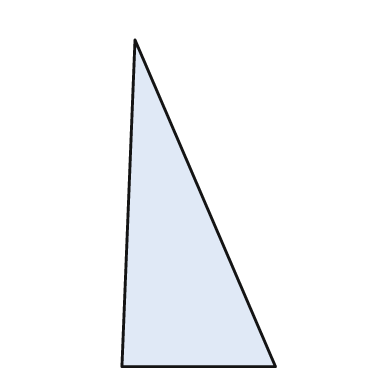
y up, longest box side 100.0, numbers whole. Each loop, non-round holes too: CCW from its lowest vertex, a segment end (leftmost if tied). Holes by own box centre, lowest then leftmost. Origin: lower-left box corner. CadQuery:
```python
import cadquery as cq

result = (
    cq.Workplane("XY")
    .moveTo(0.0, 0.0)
    .lineTo(47.0, 0.0)
    .lineTo(4.0, 100.0)
    .close()
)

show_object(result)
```